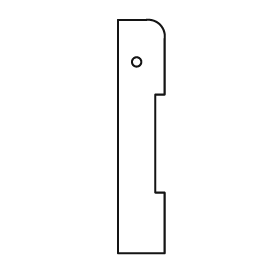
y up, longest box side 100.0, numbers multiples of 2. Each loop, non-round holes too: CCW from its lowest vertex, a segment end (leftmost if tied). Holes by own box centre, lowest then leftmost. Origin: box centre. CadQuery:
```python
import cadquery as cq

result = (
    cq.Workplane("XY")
    .moveTo(-10.0, -50.0)
    .lineTo(10.0, -50.0)
    .lineTo(10.0, -24.0)
    .lineTo(6.0, -24.0)
    .lineTo(6.0, 18.0)
    .lineTo(10.0, 18.0)
    .lineTo(10.0, 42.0)
    .threePointArc((8.0, 48.0), (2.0, 50.0))
    .lineTo(-10.0, 50.0)
    .close()
    .moveTo(-2.0, 32.0)
    .circle(2.0)
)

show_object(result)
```